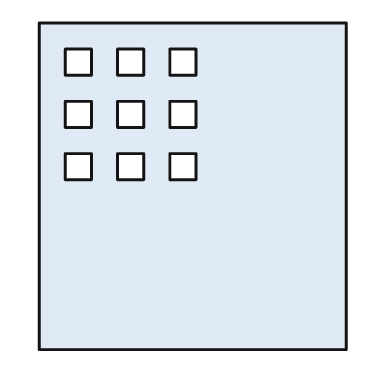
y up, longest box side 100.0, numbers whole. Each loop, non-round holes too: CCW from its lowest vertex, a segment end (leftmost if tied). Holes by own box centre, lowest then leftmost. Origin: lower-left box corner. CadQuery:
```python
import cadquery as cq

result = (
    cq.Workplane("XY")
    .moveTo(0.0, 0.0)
    .lineTo(94.0, 0.0)
    .lineTo(94.0, 100.0)
    .lineTo(0.0, 100.0)
    .close()
    .moveTo(8.0, 52.0)
    .lineTo(16.0, 52.0)
    .lineTo(16.0, 60.0)
    .lineTo(8.0, 60.0)
    .close()
    .moveTo(24.0, 52.0)
    .lineTo(32.0, 52.0)
    .lineTo(32.0, 60.0)
    .lineTo(24.0, 60.0)
    .close()
    .moveTo(40.0, 52.0)
    .lineTo(48.0, 52.0)
    .lineTo(48.0, 60.0)
    .lineTo(40.0, 60.0)
    .close()
    .moveTo(8.0, 68.0)
    .lineTo(16.0, 68.0)
    .lineTo(16.0, 76.0)
    .lineTo(8.0, 76.0)
    .close()
    .moveTo(24.0, 68.0)
    .lineTo(32.0, 68.0)
    .lineTo(32.0, 76.0)
    .lineTo(24.0, 76.0)
    .close()
    .moveTo(40.0, 68.0)
    .lineTo(48.0, 68.0)
    .lineTo(48.0, 76.0)
    .lineTo(40.0, 76.0)
    .close()
    .moveTo(8.0, 84.0)
    .lineTo(16.0, 84.0)
    .lineTo(16.0, 92.0)
    .lineTo(8.0, 92.0)
    .close()
    .moveTo(24.0, 84.0)
    .lineTo(32.0, 84.0)
    .lineTo(32.0, 92.0)
    .lineTo(24.0, 92.0)
    .close()
    .moveTo(40.0, 84.0)
    .lineTo(48.0, 84.0)
    .lineTo(48.0, 92.0)
    .lineTo(40.0, 92.0)
    .close()
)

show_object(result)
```